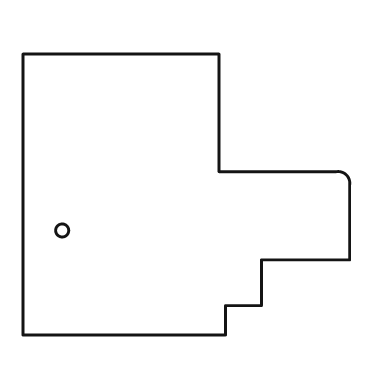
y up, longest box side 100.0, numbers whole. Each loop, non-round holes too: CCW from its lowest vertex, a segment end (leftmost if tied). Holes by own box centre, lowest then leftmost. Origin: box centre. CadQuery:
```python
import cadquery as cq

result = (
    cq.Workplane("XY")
    .moveTo(-50.0, -43.0)
    .lineTo(12.0, -43.0)
    .lineTo(12.0, -34.0)
    .lineTo(23.0, -34.0)
    .lineTo(23.0, -20.0)
    .lineTo(50.0, -20.0)
    .lineTo(50.0, 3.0)
    .threePointArc((49.0, 6.0), (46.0, 7.0))
    .lineTo(10.0, 7.0)
    .lineTo(10.0, 43.0)
    .lineTo(-50.0, 43.0)
    .close()
    .moveTo(-38.0, -11.0)
    .circle(2.0)
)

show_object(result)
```